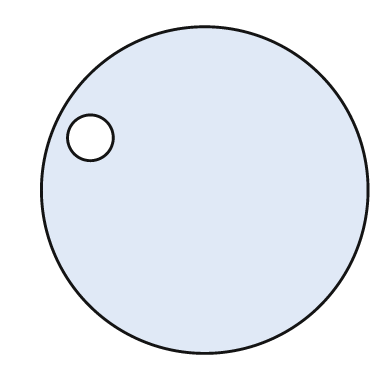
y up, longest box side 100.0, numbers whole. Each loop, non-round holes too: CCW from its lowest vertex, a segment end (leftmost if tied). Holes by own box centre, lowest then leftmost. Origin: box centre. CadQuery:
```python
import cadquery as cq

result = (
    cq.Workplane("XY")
    .moveTo(0.0, 0.0)
    .circle(50.0)
    .moveTo(-35.0, 16.0)
    .circle(7.0)
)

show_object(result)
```